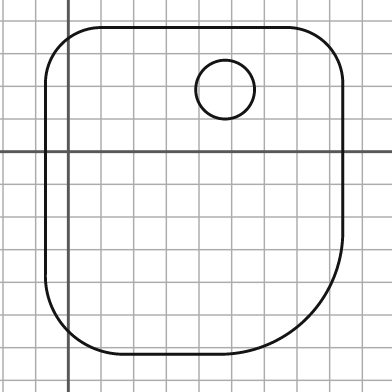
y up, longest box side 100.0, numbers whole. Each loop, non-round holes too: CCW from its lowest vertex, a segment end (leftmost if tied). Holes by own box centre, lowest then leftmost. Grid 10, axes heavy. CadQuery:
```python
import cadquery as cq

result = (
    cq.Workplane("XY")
    .moveTo(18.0, -62.0)
    .lineTo(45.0, -62.0)
    .threePointArc((73.0, -51.0), (84.0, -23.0))
    .lineTo(84.0, 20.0)
    .threePointArc((79.0, 33.0), (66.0, 38.0))
    .lineTo(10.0, 38.0)
    .threePointArc((-2.0, 33.0), (-7.0, 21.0))
    .lineTo(-7.0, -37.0)
    .threePointArc((0.0, -55.0), (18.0, -62.0))
    .close()
    .moveTo(48.0, 19.0)
    .circle(9.0)
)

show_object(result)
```